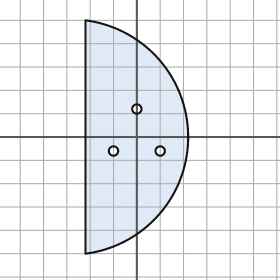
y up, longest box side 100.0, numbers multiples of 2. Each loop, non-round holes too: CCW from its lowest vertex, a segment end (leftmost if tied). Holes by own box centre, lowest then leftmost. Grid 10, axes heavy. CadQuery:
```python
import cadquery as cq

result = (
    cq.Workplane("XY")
    .moveTo(-22.0, -50.0)
    .threePointArc((22.0, 0.0), (-22.0, 50.0))
    .close()
    .moveTo(-10.0, -6.0)
    .circle(2.0)
    .moveTo(10.0, -6.0)
    .circle(2.0)
    .moveTo(0.0, 12.0)
    .circle(2.0)
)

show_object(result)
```